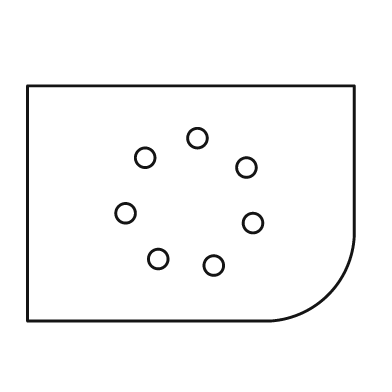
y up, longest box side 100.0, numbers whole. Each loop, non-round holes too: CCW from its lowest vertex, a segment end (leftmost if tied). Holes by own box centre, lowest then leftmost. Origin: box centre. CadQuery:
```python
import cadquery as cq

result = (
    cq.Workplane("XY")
    .moveTo(-50.0, -36.0)
    .lineTo(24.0, -36.0)
    .threePointArc((42.0, -28.0), (50.0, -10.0))
    .lineTo(50.0, 36.0)
    .lineTo(-50.0, 36.0)
    .close()
    .moveTo(7.0, -19.0)
    .circle(3.0)
    .moveTo(-10.0, -17.0)
    .circle(3.0)
    .moveTo(19.0, -6.0)
    .circle(3.0)
    .moveTo(-20.0, -3.0)
    .circle(3.0)
    .moveTo(17.0, 11.0)
    .circle(3.0)
    .moveTo(-14.0, 14.0)
    .circle(3.0)
    .moveTo(2.0, 20.0)
    .circle(3.0)
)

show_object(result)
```